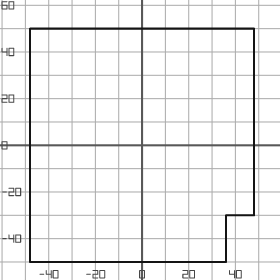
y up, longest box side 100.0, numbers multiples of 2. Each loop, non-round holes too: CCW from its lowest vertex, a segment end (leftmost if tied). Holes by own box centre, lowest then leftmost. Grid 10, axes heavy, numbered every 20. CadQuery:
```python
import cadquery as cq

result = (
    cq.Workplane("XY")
    .moveTo(-48.0, -50.0)
    .lineTo(36.0, -50.0)
    .lineTo(36.0, -30.0)
    .lineTo(48.0, -30.0)
    .lineTo(48.0, 50.0)
    .lineTo(-48.0, 50.0)
    .close()
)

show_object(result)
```